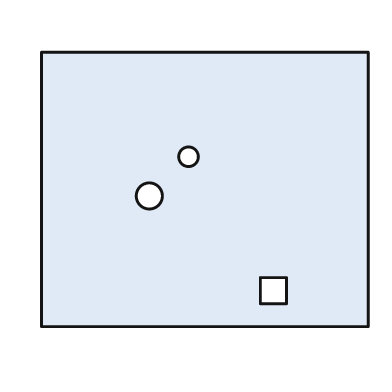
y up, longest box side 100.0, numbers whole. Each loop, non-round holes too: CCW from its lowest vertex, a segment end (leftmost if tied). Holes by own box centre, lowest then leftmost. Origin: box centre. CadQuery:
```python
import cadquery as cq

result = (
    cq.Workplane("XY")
    .moveTo(-50.0, -42.0)
    .lineTo(50.0, -42.0)
    .lineTo(50.0, 42.0)
    .lineTo(-50.0, 42.0)
    .close()
    .moveTo(17.0, -35.0)
    .lineTo(25.0, -35.0)
    .lineTo(25.0, -27.0)
    .lineTo(17.0, -27.0)
    .close()
    .moveTo(-17.0, -2.0)
    .circle(4.0)
    .moveTo(-5.0, 10.0)
    .circle(3.0)
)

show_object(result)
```